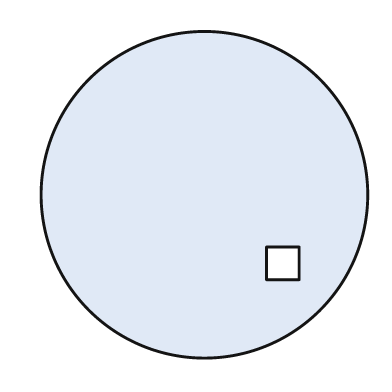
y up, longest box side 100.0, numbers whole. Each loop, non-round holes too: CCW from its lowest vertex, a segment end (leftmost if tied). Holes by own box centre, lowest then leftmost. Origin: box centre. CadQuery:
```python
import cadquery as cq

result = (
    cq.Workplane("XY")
    .moveTo(0.0, 0.0)
    .circle(50.0)
    .moveTo(19.0, -26.0)
    .lineTo(29.0, -26.0)
    .lineTo(29.0, -16.0)
    .lineTo(19.0, -16.0)
    .close()
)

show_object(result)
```